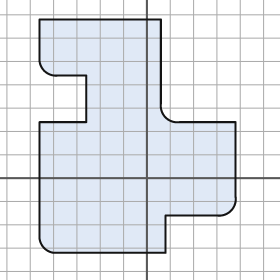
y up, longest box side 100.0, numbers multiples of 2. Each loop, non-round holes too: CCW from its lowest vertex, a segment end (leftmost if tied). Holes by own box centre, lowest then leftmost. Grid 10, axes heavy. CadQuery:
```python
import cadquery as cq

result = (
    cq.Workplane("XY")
    .moveTo(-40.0, -32.0)
    .lineTo(8.0, -32.0)
    .lineTo(8.0, -16.0)
    .lineTo(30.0, -16.0)
    .threePointArc((36.0, -14.0), (38.0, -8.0))
    .lineTo(38.0, 24.0)
    .lineTo(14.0, 24.0)
    .threePointArc((8.0, 26.0), (6.0, 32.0))
    .lineTo(6.0, 68.0)
    .lineTo(-46.0, 68.0)
    .lineTo(-46.0, 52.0)
    .threePointArc((-44.0, 46.0), (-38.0, 44.0))
    .lineTo(-26.0, 44.0)
    .lineTo(-26.0, 24.0)
    .lineTo(-46.0, 24.0)
    .lineTo(-46.0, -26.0)
    .threePointArc((-44.0, -30.0), (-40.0, -32.0))
    .close()
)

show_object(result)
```